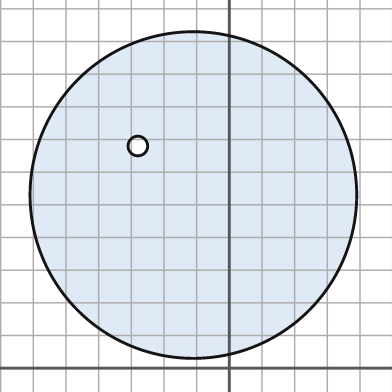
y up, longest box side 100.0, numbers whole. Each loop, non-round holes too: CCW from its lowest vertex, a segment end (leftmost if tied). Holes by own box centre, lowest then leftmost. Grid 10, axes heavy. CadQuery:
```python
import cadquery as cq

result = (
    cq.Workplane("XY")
    .moveTo(-11.0, 53.0)
    .circle(50.0)
    .moveTo(-28.0, 68.0)
    .circle(3.0)
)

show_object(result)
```